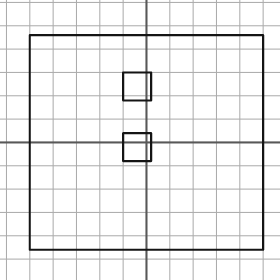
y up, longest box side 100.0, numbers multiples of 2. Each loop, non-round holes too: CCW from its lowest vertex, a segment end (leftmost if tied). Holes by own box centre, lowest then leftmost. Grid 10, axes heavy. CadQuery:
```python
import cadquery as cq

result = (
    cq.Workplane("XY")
    .moveTo(-50.0, -46.0)
    .lineTo(50.0, -46.0)
    .lineTo(50.0, 46.0)
    .lineTo(-50.0, 46.0)
    .close()
    .moveTo(-10.0, -8.0)
    .lineTo(2.0, -8.0)
    .lineTo(2.0, 4.0)
    .lineTo(-10.0, 4.0)
    .close()
    .moveTo(-10.0, 18.0)
    .lineTo(2.0, 18.0)
    .lineTo(2.0, 30.0)
    .lineTo(-10.0, 30.0)
    .close()
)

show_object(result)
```